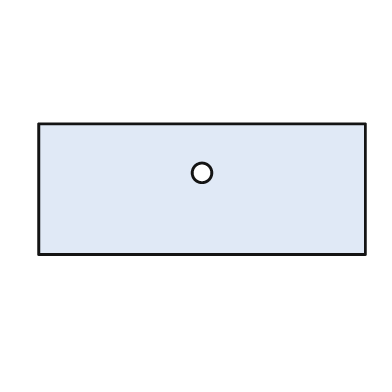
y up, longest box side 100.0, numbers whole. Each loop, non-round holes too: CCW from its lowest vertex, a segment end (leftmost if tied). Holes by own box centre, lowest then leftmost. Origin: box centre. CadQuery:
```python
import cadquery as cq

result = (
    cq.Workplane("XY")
    .moveTo(-50.0, -20.0)
    .lineTo(50.0, -20.0)
    .lineTo(50.0, 20.0)
    .lineTo(-50.0, 20.0)
    .close()
    .moveTo(0.0, 5.0)
    .circle(3.0)
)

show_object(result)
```